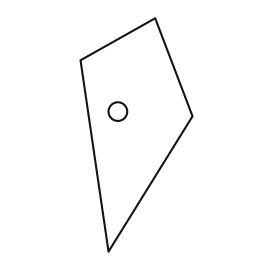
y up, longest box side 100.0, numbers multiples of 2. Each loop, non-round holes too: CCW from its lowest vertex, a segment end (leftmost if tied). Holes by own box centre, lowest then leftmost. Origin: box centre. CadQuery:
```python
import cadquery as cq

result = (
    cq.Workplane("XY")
    .moveTo(-12.0, -50.0)
    .lineTo(24.0, 8.0)
    .lineTo(8.0, 50.0)
    .lineTo(-24.0, 32.0)
    .close()
    .moveTo(-8.0, 10.0)
    .circle(4.0)
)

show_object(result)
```